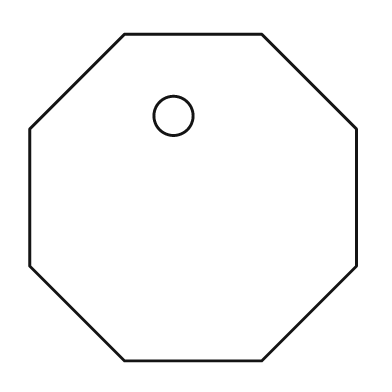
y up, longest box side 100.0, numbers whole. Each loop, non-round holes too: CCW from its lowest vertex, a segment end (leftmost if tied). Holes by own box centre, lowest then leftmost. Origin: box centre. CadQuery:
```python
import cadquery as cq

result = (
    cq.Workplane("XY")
    .moveTo(-21.0, -50.0)
    .lineTo(21.0, -50.0)
    .lineTo(50.0, -21.0)
    .lineTo(50.0, 21.0)
    .lineTo(21.0, 50.0)
    .lineTo(-21.0, 50.0)
    .lineTo(-50.0, 21.0)
    .lineTo(-50.0, -21.0)
    .close()
    .moveTo(-6.0, 25.0)
    .circle(6.0)
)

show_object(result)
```